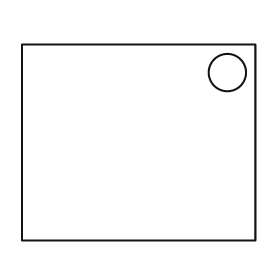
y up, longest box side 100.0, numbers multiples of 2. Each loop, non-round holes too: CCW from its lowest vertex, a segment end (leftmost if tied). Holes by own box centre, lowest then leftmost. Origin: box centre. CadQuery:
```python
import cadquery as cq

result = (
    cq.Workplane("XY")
    .moveTo(-50.0, -42.0)
    .lineTo(50.0, -42.0)
    .lineTo(50.0, 42.0)
    .lineTo(-50.0, 42.0)
    .close()
    .moveTo(38.0, 30.0)
    .circle(8.0)
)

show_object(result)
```